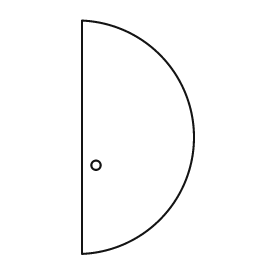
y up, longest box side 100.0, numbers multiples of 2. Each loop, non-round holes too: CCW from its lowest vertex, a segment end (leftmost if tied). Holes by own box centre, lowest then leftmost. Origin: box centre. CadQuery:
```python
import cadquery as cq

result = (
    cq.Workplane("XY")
    .moveTo(-24.0, -50.0)
    .threePointArc((24.0, 0.0), (-24.0, 50.0))
    .close()
    .moveTo(-18.0, -12.0)
    .circle(2.0)
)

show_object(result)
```